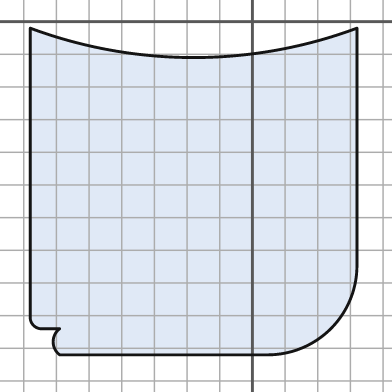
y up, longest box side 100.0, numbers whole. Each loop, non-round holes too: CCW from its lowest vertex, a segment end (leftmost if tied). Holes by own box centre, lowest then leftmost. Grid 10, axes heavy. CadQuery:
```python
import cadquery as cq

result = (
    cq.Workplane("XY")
    .moveTo(-59.0, -102.0)
    .lineTo(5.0, -102.0)
    .threePointArc((24.0, -94.0), (32.0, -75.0))
    .lineTo(32.0, -2.0)
    .threePointArc((-18.0, -11.0), (-68.0, -2.0))
    .lineTo(-68.0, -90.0)
    .threePointArc((-67.0, -93.0), (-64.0, -94.0))
    .lineTo(-59.0, -94.0)
    .threePointArc((-61.0, -98.0), (-59.0, -102.0))
    .close()
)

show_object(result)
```